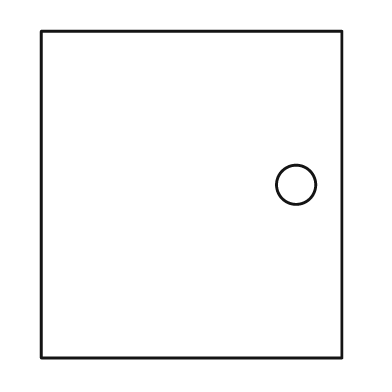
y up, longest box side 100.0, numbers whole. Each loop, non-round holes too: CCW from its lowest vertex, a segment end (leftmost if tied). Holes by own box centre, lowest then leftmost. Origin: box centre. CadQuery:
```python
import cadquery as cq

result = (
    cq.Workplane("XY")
    .moveTo(-46.0, -50.0)
    .lineTo(46.0, -50.0)
    .lineTo(46.0, 50.0)
    .lineTo(-46.0, 50.0)
    .close()
    .moveTo(32.0, 3.0)
    .circle(6.0)
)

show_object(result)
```